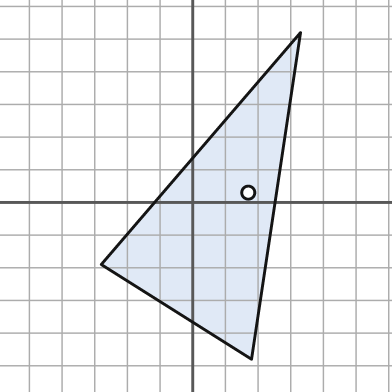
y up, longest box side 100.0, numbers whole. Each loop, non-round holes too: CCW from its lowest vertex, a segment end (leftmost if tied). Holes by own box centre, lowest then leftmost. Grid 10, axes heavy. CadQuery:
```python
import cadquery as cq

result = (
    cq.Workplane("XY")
    .moveTo(18.0, -48.0)
    .lineTo(33.0, 52.0)
    .lineTo(-28.0, -19.0)
    .close()
    .moveTo(17.0, 3.0)
    .circle(2.0)
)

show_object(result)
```